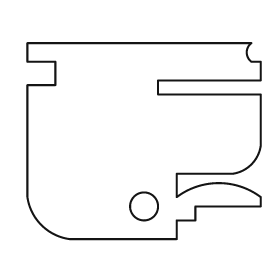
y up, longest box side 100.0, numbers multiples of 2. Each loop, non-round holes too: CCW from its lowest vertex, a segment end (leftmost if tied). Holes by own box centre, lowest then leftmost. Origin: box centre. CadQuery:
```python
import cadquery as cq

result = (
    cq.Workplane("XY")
    .moveTo(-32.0, -42.0)
    .lineTo(14.0, -42.0)
    .lineTo(14.0, -34.0)
    .lineTo(22.0, -34.0)
    .lineTo(22.0, -28.0)
    .lineTo(50.0, -28.0)
    .lineTo(50.0, -24.0)
    .threePointArc((32.0, -18.0), (14.0, -24.0))
    .lineTo(14.0, -14.0)
    .lineTo(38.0, -14.0)
    .threePointArc((46.0, -10.0), (50.0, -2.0))
    .lineTo(50.0, 20.0)
    .lineTo(6.0, 20.0)
    .lineTo(6.0, 26.0)
    .lineTo(50.0, 26.0)
    .lineTo(50.0, 34.0)
    .lineTo(46.0, 34.0)
    .threePointArc((44.0, 38.0), (46.0, 42.0))
    .lineTo(-50.0, 42.0)
    .lineTo(-50.0, 34.0)
    .lineTo(-38.0, 34.0)
    .lineTo(-38.0, 24.0)
    .lineTo(-50.0, 24.0)
    .lineTo(-50.0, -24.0)
    .threePointArc((-44.0, -36.0), (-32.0, -42.0))
    .close()
    .moveTo(0.0, -28.0)
    .circle(6.0)
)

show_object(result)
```